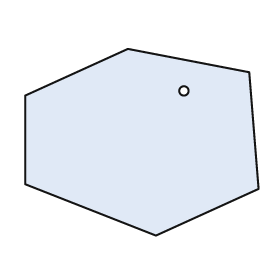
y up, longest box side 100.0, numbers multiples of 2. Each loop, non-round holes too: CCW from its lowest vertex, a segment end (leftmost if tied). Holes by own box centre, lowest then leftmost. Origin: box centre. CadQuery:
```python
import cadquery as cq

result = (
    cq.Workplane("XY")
    .moveTo(6.0, -40.0)
    .lineTo(50.0, -20.0)
    .lineTo(46.0, 30.0)
    .lineTo(-6.0, 40.0)
    .lineTo(-50.0, 20.0)
    .lineTo(-50.0, -18.0)
    .close()
    .moveTo(18.0, 22.0)
    .circle(2.0)
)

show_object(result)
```